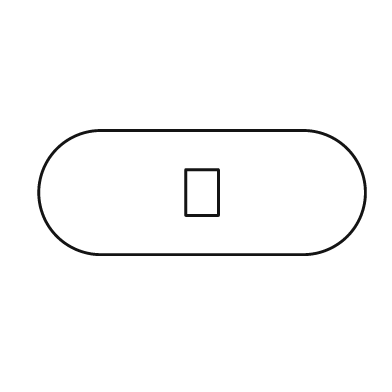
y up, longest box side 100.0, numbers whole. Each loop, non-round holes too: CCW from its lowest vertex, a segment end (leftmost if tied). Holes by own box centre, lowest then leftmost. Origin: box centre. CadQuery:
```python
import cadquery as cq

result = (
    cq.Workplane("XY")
    .moveTo(-31.0, -19.0)
    .lineTo(31.0, -19.0)
    .threePointArc((50.0, 0.0), (31.0, 19.0))
    .lineTo(-31.0, 19.0)
    .threePointArc((-50.0, 0.0), (-31.0, -19.0))
    .close()
    .moveTo(-5.0, -7.0)
    .lineTo(5.0, -7.0)
    .lineTo(5.0, 7.0)
    .lineTo(-5.0, 7.0)
    .close()
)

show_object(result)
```